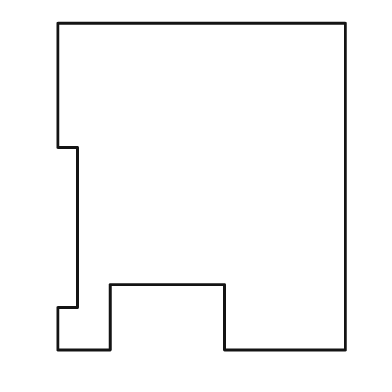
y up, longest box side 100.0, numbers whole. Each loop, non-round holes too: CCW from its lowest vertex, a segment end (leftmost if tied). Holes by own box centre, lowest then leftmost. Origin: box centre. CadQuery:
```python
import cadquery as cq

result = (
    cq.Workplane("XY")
    .moveTo(-44.0, -50.0)
    .lineTo(-28.0, -50.0)
    .lineTo(-28.0, -30.0)
    .lineTo(7.0, -30.0)
    .lineTo(7.0, -50.0)
    .lineTo(44.0, -50.0)
    .lineTo(44.0, 50.0)
    .lineTo(-44.0, 50.0)
    .lineTo(-44.0, 12.0)
    .lineTo(-38.0, 12.0)
    .lineTo(-38.0, -37.0)
    .lineTo(-44.0, -37.0)
    .close()
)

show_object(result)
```